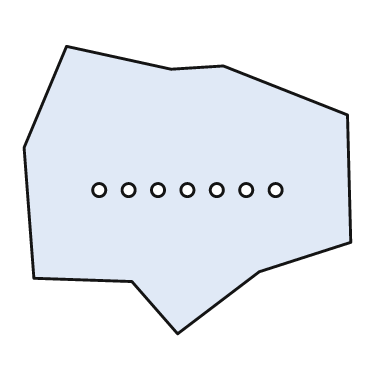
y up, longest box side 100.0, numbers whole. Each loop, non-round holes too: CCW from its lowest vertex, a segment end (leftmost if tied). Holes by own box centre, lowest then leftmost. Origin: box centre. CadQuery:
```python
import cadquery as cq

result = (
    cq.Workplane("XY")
    .moveTo(-3.0, -44.0)
    .lineTo(22.0, -25.0)
    .lineTo(50.0, -16.0)
    .lineTo(49.0, 23.0)
    .lineTo(11.0, 38.0)
    .lineTo(-5.0, 37.0)
    .lineTo(-37.0, 44.0)
    .lineTo(-50.0, 13.0)
    .lineTo(-47.0, -27.0)
    .lineTo(-17.0, -28.0)
    .close()
    .moveTo(-27.0, 0.0)
    .circle(2.0)
    .moveTo(-18.0, 0.0)
    .circle(2.0)
    .moveTo(-9.0, 0.0)
    .circle(2.0)
    .moveTo(0.0, 0.0)
    .circle(2.0)
    .moveTo(9.0, 0.0)
    .circle(2.0)
    .moveTo(18.0, 0.0)
    .circle(2.0)
    .moveTo(27.0, 0.0)
    .circle(2.0)
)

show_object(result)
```